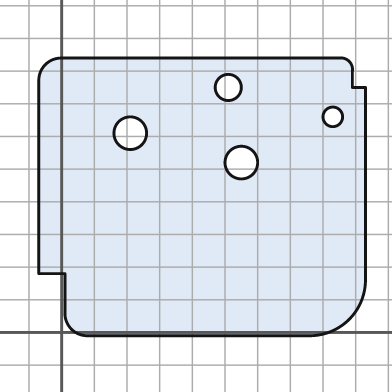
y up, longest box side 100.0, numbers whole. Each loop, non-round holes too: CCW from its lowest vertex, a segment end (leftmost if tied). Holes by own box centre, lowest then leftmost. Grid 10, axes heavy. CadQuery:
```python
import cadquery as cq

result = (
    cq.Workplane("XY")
    .moveTo(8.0, -1.0)
    .lineTo(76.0, -1.0)
    .threePointArc((88.0, 4.0), (93.0, 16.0))
    .lineTo(93.0, 75.0)
    .lineTo(89.0, 75.0)
    .lineTo(89.0, 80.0)
    .threePointArc((88.0, 83.0), (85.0, 84.0))
    .lineTo(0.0, 84.0)
    .threePointArc((-5.0, 82.0), (-7.0, 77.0))
    .lineTo(-7.0, 18.0)
    .lineTo(1.0, 18.0)
    .lineTo(1.0, 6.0)
    .threePointArc((3.0, 1.0), (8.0, -1.0))
    .close()
    .moveTo(55.0, 52.0)
    .circle(5.0)
    .moveTo(21.0, 61.0)
    .circle(5.0)
    .moveTo(83.0, 66.0)
    .circle(3.0)
    .moveTo(51.0, 75.0)
    .circle(4.0)
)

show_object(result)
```